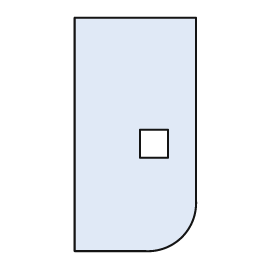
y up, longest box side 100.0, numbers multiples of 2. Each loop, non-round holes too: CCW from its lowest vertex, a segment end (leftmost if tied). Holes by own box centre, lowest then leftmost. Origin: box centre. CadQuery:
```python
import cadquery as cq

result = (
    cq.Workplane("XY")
    .moveTo(-26.0, -50.0)
    .lineTo(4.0, -50.0)
    .threePointArc((20.0, -44.0), (26.0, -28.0))
    .lineTo(26.0, 50.0)
    .lineTo(-26.0, 50.0)
    .close()
    .moveTo(2.0, -10.0)
    .lineTo(14.0, -10.0)
    .lineTo(14.0, 2.0)
    .lineTo(2.0, 2.0)
    .close()
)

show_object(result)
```